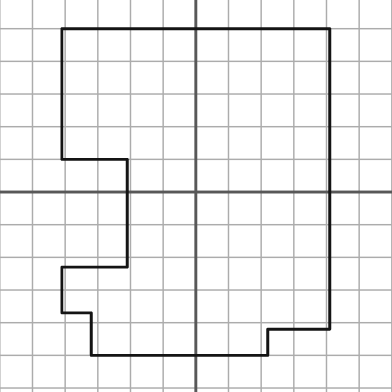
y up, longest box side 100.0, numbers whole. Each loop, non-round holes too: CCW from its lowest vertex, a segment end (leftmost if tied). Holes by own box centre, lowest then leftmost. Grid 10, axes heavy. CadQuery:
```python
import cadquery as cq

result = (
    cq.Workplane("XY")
    .moveTo(-32.0, -50.0)
    .lineTo(22.0, -50.0)
    .lineTo(22.0, -42.0)
    .lineTo(41.0, -42.0)
    .lineTo(41.0, 50.0)
    .lineTo(-41.0, 50.0)
    .lineTo(-41.0, 10.0)
    .lineTo(-21.0, 10.0)
    .lineTo(-21.0, -23.0)
    .lineTo(-41.0, -23.0)
    .lineTo(-41.0, -37.0)
    .lineTo(-32.0, -37.0)
    .close()
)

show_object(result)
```